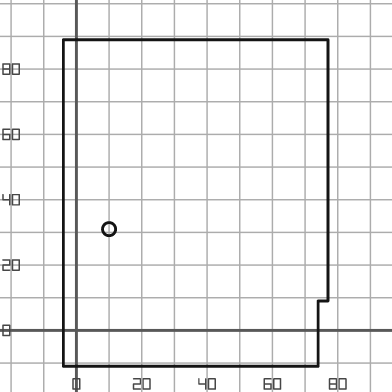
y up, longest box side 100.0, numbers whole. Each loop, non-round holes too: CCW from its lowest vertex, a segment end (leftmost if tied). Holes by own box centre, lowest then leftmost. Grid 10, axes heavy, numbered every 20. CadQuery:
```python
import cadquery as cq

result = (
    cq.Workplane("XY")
    .moveTo(-4.0, -11.0)
    .lineTo(74.0, -11.0)
    .lineTo(74.0, 9.0)
    .lineTo(77.0, 9.0)
    .lineTo(77.0, 89.0)
    .lineTo(-4.0, 89.0)
    .close()
    .moveTo(10.0, 31.0)
    .circle(2.0)
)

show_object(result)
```